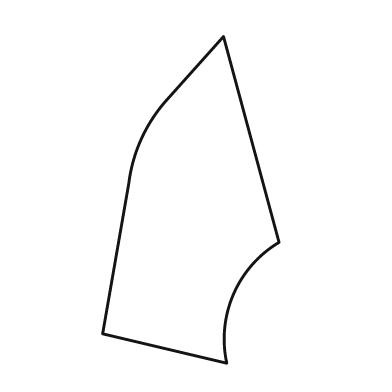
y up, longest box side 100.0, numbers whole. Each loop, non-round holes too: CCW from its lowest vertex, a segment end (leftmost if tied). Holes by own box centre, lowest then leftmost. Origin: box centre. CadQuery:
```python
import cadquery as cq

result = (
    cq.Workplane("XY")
    .moveTo(11.0, -50.0)
    .threePointArc((13.0, -29.0), (27.0, -13.0))
    .lineTo(10.0, 50.0)
    .lineTo(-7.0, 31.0)
    .threePointArc((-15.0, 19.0), (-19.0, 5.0))
    .lineTo(-27.0, -41.0)
    .close()
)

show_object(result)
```